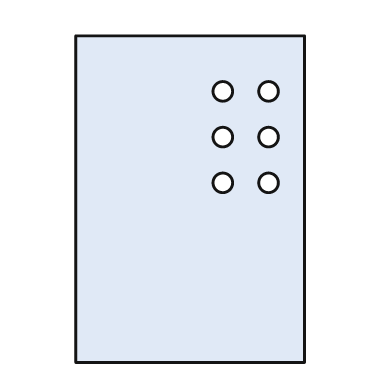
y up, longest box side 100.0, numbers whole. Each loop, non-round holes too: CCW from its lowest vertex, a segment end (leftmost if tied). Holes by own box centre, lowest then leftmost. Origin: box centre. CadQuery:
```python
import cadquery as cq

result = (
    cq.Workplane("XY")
    .moveTo(-35.0, -50.0)
    .lineTo(35.0, -50.0)
    .lineTo(35.0, 50.0)
    .lineTo(-35.0, 50.0)
    .close()
    .moveTo(10.0, 5.0)
    .circle(3.0)
    .moveTo(24.0, 5.0)
    .circle(3.0)
    .moveTo(10.0, 19.0)
    .circle(3.0)
    .moveTo(24.0, 19.0)
    .circle(3.0)
    .moveTo(10.0, 33.0)
    .circle(3.0)
    .moveTo(24.0, 33.0)
    .circle(3.0)
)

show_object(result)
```